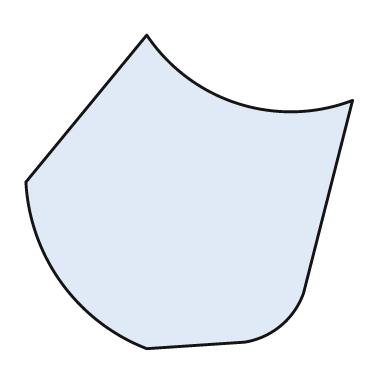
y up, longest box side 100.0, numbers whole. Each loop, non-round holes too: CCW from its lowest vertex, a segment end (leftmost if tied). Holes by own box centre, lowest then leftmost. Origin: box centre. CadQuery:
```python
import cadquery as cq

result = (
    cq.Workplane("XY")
    .moveTo(-13.0, -48.0)
    .lineTo(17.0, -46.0)
    .threePointArc((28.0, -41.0), (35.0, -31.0))
    .lineTo(50.0, 28.0)
    .threePointArc((15.0, 27.0), (-13.0, 48.0))
    .lineTo(-50.0, 3.0)
    .threePointArc((-39.0, -28.0), (-13.0, -48.0))
    .close()
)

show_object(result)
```